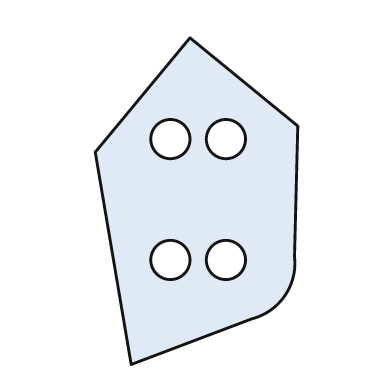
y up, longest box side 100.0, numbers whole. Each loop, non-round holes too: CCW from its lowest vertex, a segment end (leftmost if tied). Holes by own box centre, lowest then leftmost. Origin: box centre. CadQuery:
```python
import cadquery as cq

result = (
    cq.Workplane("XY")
    .moveTo(-20.0, -50.0)
    .lineTo(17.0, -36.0)
    .threePointArc((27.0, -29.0), (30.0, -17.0))
    .lineTo(31.0, 23.0)
    .lineTo(-2.0, 50.0)
    .lineTo(-31.0, 15.0)
    .close()
    .moveTo(-8.0, -18.0)
    .circle(6.0)
    .moveTo(9.0, -18.0)
    .circle(6.0)
    .moveTo(-8.0, 19.0)
    .circle(6.0)
    .moveTo(9.0, 19.0)
    .circle(6.0)
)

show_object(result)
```